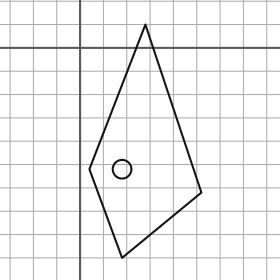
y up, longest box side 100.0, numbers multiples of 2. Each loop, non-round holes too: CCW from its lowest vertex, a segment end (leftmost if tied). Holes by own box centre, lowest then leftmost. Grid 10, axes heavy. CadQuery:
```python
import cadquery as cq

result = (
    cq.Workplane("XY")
    .moveTo(18.0, -90.0)
    .lineTo(52.0, -62.0)
    .lineTo(28.0, 10.0)
    .lineTo(4.0, -52.0)
    .close()
    .moveTo(18.0, -52.0)
    .circle(4.0)
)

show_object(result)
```